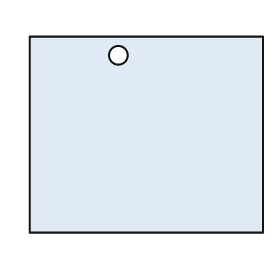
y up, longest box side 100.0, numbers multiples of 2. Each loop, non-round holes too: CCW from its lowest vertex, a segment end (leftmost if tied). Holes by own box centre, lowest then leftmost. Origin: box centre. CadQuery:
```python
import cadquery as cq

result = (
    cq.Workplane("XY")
    .moveTo(-50.0, -42.0)
    .lineTo(50.0, -42.0)
    .lineTo(50.0, 42.0)
    .lineTo(-50.0, 42.0)
    .close()
    .moveTo(-12.0, 34.0)
    .circle(4.0)
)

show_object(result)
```